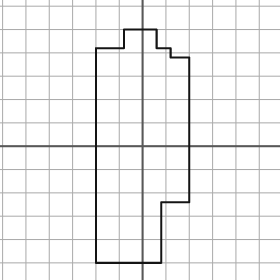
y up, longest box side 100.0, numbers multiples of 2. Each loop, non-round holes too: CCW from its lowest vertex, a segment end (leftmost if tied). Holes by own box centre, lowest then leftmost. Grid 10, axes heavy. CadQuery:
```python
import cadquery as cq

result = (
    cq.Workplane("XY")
    .moveTo(-20.0, -50.0)
    .lineTo(8.0, -50.0)
    .lineTo(8.0, -24.0)
    .lineTo(20.0, -24.0)
    .lineTo(20.0, 38.0)
    .lineTo(12.0, 38.0)
    .lineTo(12.0, 42.0)
    .lineTo(6.0, 42.0)
    .lineTo(6.0, 50.0)
    .lineTo(-8.0, 50.0)
    .lineTo(-8.0, 42.0)
    .lineTo(-20.0, 42.0)
    .close()
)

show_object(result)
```